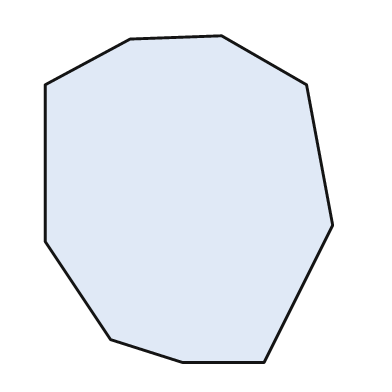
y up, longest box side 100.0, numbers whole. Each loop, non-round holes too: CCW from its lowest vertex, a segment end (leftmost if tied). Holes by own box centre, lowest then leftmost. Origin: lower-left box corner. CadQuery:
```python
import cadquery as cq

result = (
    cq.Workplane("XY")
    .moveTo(42.0, 0.0)
    .lineTo(67.0, 0.0)
    .lineTo(88.0, 42.0)
    .lineTo(80.0, 85.0)
    .lineTo(54.0, 100.0)
    .lineTo(26.0, 99.0)
    .lineTo(0.0, 85.0)
    .lineTo(0.0, 37.0)
    .lineTo(20.0, 7.0)
    .close()
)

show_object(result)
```